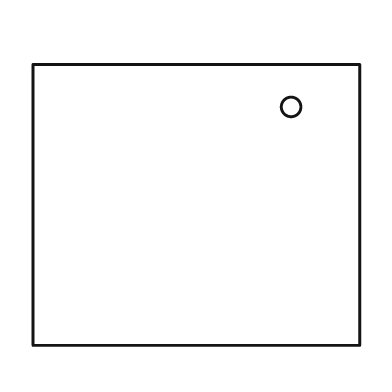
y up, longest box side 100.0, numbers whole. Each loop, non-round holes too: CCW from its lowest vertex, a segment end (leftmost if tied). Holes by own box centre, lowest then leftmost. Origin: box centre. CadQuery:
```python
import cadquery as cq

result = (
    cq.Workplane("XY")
    .moveTo(-50.0, -43.0)
    .lineTo(50.0, -43.0)
    .lineTo(50.0, 43.0)
    .lineTo(-50.0, 43.0)
    .close()
    .moveTo(29.0, 30.0)
    .circle(3.0)
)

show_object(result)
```